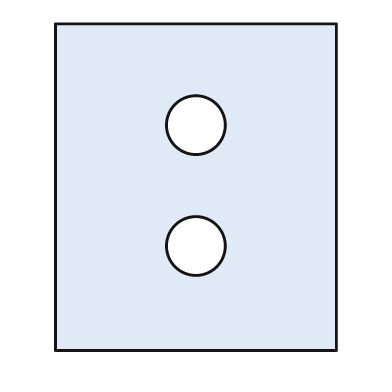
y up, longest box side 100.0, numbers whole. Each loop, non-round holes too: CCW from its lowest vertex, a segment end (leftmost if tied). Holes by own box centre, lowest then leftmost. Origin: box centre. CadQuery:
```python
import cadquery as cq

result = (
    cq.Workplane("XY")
    .moveTo(-43.0, -50.0)
    .lineTo(43.0, -50.0)
    .lineTo(43.0, 50.0)
    .lineTo(-43.0, 50.0)
    .close()
    .moveTo(0.0, -18.0)
    .circle(9.0)
    .moveTo(0.0, 19.0)
    .circle(9.0)
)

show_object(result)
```